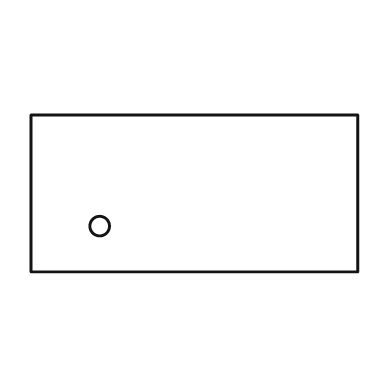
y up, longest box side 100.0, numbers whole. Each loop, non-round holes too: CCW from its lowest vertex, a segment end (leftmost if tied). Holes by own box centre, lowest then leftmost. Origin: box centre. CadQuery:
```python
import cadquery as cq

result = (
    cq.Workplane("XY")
    .moveTo(-50.0, -24.0)
    .lineTo(50.0, -24.0)
    .lineTo(50.0, 24.0)
    .lineTo(-50.0, 24.0)
    .close()
    .moveTo(-29.0, -10.0)
    .circle(3.0)
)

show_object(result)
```